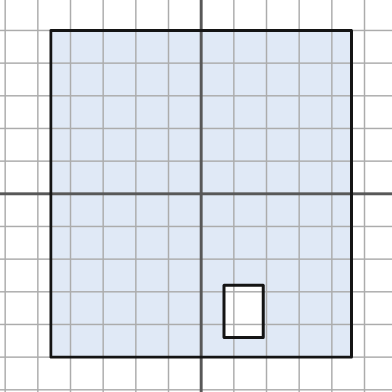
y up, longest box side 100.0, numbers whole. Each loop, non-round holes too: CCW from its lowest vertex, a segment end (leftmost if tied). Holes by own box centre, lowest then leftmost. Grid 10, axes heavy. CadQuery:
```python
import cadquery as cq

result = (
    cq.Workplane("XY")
    .moveTo(-46.0, -50.0)
    .lineTo(46.0, -50.0)
    .lineTo(46.0, 50.0)
    .lineTo(-46.0, 50.0)
    .close()
    .moveTo(7.0, -44.0)
    .lineTo(19.0, -44.0)
    .lineTo(19.0, -28.0)
    .lineTo(7.0, -28.0)
    .close()
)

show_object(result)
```